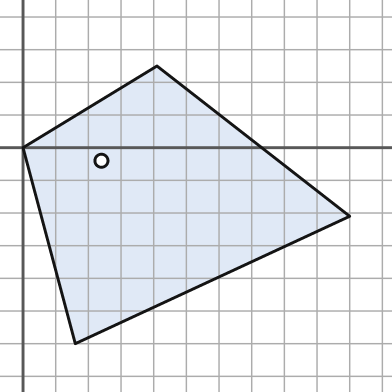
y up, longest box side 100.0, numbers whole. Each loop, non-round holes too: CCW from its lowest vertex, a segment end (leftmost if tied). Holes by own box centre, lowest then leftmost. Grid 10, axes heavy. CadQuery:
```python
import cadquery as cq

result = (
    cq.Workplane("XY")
    .moveTo(16.0, -60.0)
    .lineTo(100.0, -21.0)
    .lineTo(41.0, 25.0)
    .lineTo(0.0, 0.0)
    .close()
    .moveTo(24.0, -4.0)
    .circle(2.0)
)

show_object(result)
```